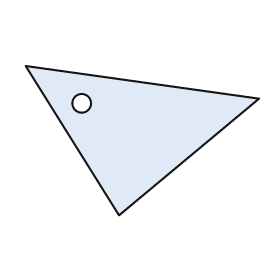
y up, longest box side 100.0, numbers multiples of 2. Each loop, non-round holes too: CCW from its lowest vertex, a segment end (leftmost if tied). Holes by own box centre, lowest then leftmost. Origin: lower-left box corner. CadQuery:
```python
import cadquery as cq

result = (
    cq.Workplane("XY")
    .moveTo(40.0, 0.0)
    .lineTo(100.0, 50.0)
    .lineTo(0.0, 64.0)
    .close()
    .moveTo(24.0, 48.0)
    .circle(4.0)
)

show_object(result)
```